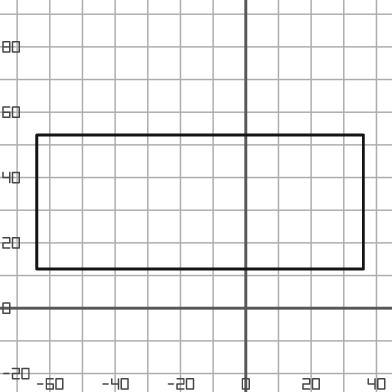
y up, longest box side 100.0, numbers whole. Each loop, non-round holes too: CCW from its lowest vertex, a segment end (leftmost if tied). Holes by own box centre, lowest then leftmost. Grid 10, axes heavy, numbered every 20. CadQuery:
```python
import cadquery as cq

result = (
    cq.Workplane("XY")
    .moveTo(-64.0, 12.0)
    .lineTo(36.0, 12.0)
    .lineTo(36.0, 53.0)
    .lineTo(-64.0, 53.0)
    .close()
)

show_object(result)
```